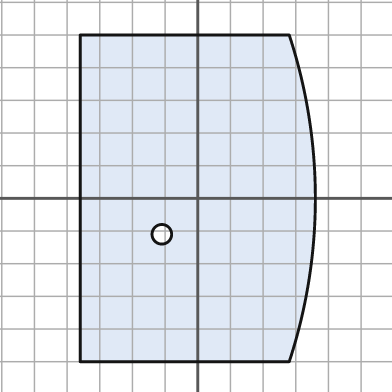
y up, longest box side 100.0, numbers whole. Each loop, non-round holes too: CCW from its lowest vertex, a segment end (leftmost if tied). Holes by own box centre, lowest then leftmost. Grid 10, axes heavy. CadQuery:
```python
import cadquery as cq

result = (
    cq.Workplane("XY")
    .moveTo(-36.0, -50.0)
    .lineTo(28.0, -50.0)
    .threePointArc((36.0, 0.0), (28.0, 50.0))
    .lineTo(-36.0, 50.0)
    .close()
    .moveTo(-11.0, -11.0)
    .circle(3.0)
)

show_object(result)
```